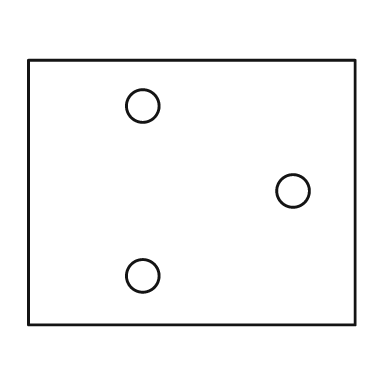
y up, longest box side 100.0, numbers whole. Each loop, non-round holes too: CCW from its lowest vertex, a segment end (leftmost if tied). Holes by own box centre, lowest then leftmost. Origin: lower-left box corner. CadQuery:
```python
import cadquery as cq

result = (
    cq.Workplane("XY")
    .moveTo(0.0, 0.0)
    .lineTo(100.0, 0.0)
    .lineTo(100.0, 81.0)
    .lineTo(0.0, 81.0)
    .close()
    .moveTo(35.0, 15.0)
    .circle(5.0)
    .moveTo(81.0, 41.0)
    .circle(5.0)
    .moveTo(35.0, 67.0)
    .circle(5.0)
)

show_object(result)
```